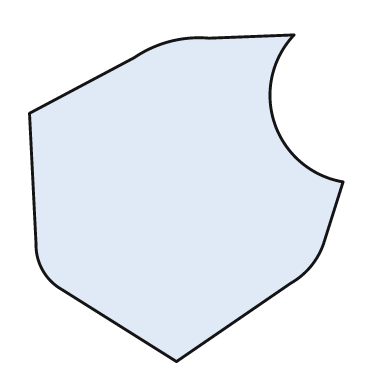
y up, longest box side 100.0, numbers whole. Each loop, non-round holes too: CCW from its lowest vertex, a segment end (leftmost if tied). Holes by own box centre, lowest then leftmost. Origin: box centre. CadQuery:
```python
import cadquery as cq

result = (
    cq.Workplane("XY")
    .moveTo(-3.0, -50.0)
    .lineTo(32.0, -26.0)
    .threePointArc((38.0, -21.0), (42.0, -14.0))
    .lineTo(48.0, 5.0)
    .threePointArc((27.0, 23.0), (33.0, 50.0))
    .lineTo(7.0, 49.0)
    .threePointArc((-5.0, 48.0), (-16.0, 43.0))
    .lineTo(-48.0, 26.0)
    .lineTo(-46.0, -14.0)
    .threePointArc((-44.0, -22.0), (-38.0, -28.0))
    .close()
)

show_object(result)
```